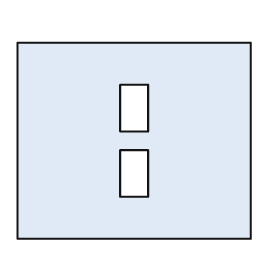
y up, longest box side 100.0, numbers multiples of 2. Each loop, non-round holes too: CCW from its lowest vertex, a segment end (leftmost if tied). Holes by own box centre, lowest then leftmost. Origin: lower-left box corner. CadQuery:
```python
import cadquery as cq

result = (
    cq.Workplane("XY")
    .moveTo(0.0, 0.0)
    .lineTo(100.0, 0.0)
    .lineTo(100.0, 84.0)
    .lineTo(0.0, 84.0)
    .close()
    .moveTo(44.0, 18.0)
    .lineTo(56.0, 18.0)
    .lineTo(56.0, 38.0)
    .lineTo(44.0, 38.0)
    .close()
    .moveTo(44.0, 46.0)
    .lineTo(56.0, 46.0)
    .lineTo(56.0, 66.0)
    .lineTo(44.0, 66.0)
    .close()
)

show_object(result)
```